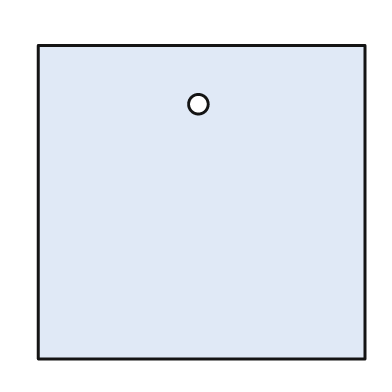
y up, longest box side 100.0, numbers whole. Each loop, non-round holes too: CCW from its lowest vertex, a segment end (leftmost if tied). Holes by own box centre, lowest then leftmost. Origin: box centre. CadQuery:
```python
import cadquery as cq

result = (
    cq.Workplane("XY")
    .moveTo(-50.0, -48.0)
    .lineTo(50.0, -48.0)
    .lineTo(50.0, 48.0)
    .lineTo(-50.0, 48.0)
    .close()
    .moveTo(-1.0, 30.0)
    .circle(3.0)
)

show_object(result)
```